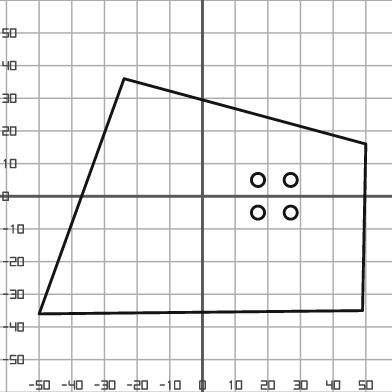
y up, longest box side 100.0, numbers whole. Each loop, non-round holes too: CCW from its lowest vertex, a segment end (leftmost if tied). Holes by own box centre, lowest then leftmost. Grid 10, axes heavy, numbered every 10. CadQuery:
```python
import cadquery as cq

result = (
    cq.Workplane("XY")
    .moveTo(-50.0, -36.0)
    .lineTo(49.0, -35.0)
    .lineTo(50.0, 16.0)
    .lineTo(-24.0, 36.0)
    .close()
    .moveTo(17.0, -5.0)
    .circle(2.0)
    .moveTo(27.0, -5.0)
    .circle(2.0)
    .moveTo(17.0, 5.0)
    .circle(2.0)
    .moveTo(27.0, 5.0)
    .circle(2.0)
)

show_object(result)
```